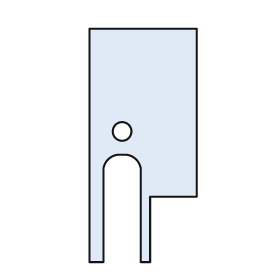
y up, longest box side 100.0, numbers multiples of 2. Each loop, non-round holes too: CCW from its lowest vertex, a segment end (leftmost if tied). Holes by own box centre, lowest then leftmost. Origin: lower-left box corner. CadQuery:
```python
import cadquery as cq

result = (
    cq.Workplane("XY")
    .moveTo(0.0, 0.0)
    .lineTo(6.0, 0.0)
    .lineTo(6.0, 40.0)
    .threePointArc((8.0, 44.0), (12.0, 46.0))
    .lineTo(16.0, 46.0)
    .threePointArc((20.0, 44.0), (22.0, 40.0))
    .lineTo(22.0, 0.0)
    .lineTo(26.0, 0.0)
    .lineTo(26.0, 28.0)
    .lineTo(46.0, 28.0)
    .lineTo(46.0, 100.0)
    .lineTo(0.0, 100.0)
    .close()
    .moveTo(14.0, 56.0)
    .circle(4.0)
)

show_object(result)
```